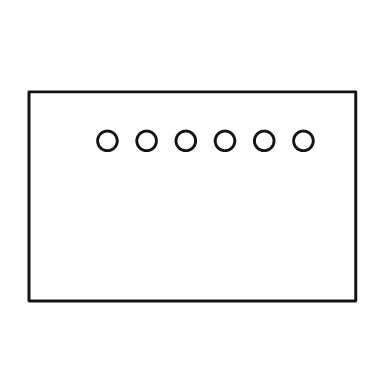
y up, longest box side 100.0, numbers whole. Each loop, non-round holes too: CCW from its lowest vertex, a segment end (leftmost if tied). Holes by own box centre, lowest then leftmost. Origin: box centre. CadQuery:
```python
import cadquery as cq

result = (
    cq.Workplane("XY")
    .moveTo(-50.0, -32.0)
    .lineTo(50.0, -32.0)
    .lineTo(50.0, 32.0)
    .lineTo(-50.0, 32.0)
    .close()
    .moveTo(-26.0, 17.0)
    .circle(3.0)
    .moveTo(-14.0, 17.0)
    .circle(3.0)
    .moveTo(-2.0, 17.0)
    .circle(3.0)
    .moveTo(10.0, 17.0)
    .circle(3.0)
    .moveTo(22.0, 17.0)
    .circle(3.0)
    .moveTo(34.0, 17.0)
    .circle(3.0)
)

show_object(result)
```